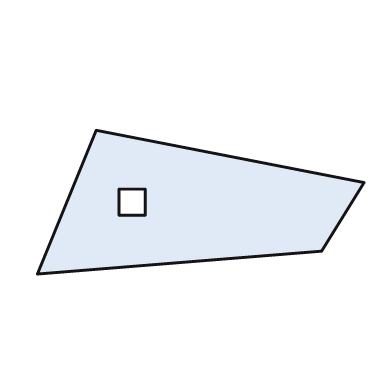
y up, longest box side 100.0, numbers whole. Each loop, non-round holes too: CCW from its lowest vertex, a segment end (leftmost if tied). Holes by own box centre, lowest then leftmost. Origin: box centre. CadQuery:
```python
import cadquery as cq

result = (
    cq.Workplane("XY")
    .moveTo(-50.0, -22.0)
    .lineTo(37.0, -15.0)
    .lineTo(50.0, 6.0)
    .lineTo(-32.0, 22.0)
    .close()
    .moveTo(-25.0, -4.0)
    .lineTo(-17.0, -4.0)
    .lineTo(-17.0, 4.0)
    .lineTo(-25.0, 4.0)
    .close()
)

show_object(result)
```